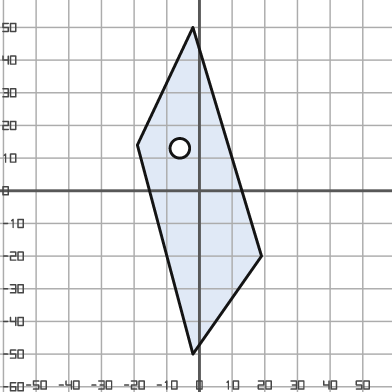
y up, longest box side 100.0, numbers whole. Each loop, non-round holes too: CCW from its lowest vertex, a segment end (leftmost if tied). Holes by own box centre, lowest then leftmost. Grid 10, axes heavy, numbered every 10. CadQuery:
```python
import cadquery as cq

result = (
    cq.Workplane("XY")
    .moveTo(-2.0, -50.0)
    .lineTo(19.0, -20.0)
    .lineTo(-2.0, 50.0)
    .lineTo(-19.0, 14.0)
    .close()
    .moveTo(-6.0, 13.0)
    .circle(3.0)
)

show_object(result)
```